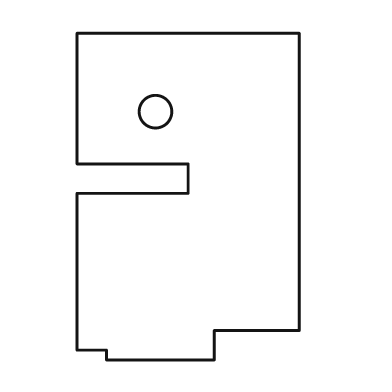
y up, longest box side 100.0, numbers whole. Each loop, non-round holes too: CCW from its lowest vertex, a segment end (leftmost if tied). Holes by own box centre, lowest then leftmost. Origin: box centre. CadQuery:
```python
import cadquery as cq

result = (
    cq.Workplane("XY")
    .moveTo(-25.0, -50.0)
    .lineTo(8.0, -50.0)
    .lineTo(8.0, -41.0)
    .lineTo(34.0, -41.0)
    .lineTo(34.0, 50.0)
    .lineTo(-34.0, 50.0)
    .lineTo(-34.0, 10.0)
    .lineTo(0.0, 10.0)
    .lineTo(0.0, 1.0)
    .lineTo(-34.0, 1.0)
    .lineTo(-34.0, -47.0)
    .lineTo(-25.0, -47.0)
    .close()
    .moveTo(-10.0, 26.0)
    .circle(5.0)
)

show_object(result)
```